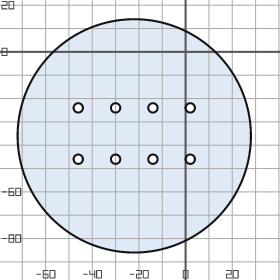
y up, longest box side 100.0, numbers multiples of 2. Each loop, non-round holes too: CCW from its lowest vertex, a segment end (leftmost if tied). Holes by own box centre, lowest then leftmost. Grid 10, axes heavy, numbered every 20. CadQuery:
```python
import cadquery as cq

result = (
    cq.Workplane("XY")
    .moveTo(-22.0, -36.0)
    .circle(50.0)
    .moveTo(-46.0, -46.0)
    .circle(2.0)
    .moveTo(-30.0, -46.0)
    .circle(2.0)
    .moveTo(-14.0, -46.0)
    .circle(2.0)
    .moveTo(2.0, -46.0)
    .circle(2.0)
    .moveTo(-46.0, -24.0)
    .circle(2.0)
    .moveTo(-30.0, -24.0)
    .circle(2.0)
    .moveTo(-14.0, -24.0)
    .circle(2.0)
    .moveTo(2.0, -24.0)
    .circle(2.0)
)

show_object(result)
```